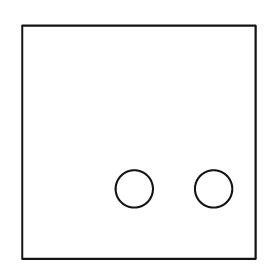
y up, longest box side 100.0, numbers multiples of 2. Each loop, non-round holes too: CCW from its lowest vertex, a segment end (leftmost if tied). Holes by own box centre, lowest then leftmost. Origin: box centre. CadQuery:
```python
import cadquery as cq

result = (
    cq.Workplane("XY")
    .moveTo(-50.0, -50.0)
    .lineTo(50.0, -50.0)
    .lineTo(50.0, 50.0)
    .lineTo(-50.0, 50.0)
    .close()
    .moveTo(-2.0, -20.0)
    .circle(8.0)
    .moveTo(32.0, -20.0)
    .circle(8.0)
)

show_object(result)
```